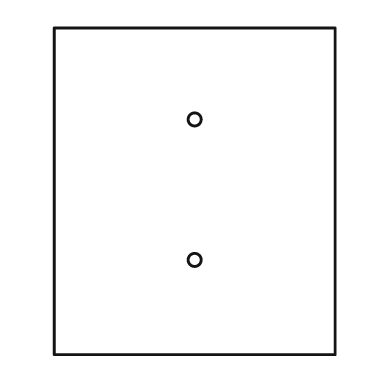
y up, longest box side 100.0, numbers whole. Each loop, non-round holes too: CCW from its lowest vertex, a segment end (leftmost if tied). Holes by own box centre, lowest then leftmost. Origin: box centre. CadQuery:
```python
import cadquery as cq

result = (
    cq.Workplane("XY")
    .moveTo(-43.0, -50.0)
    .lineTo(43.0, -50.0)
    .lineTo(43.0, 50.0)
    .lineTo(-43.0, 50.0)
    .close()
    .moveTo(0.0, -21.0)
    .circle(2.0)
    .moveTo(0.0, 22.0)
    .circle(2.0)
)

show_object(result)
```